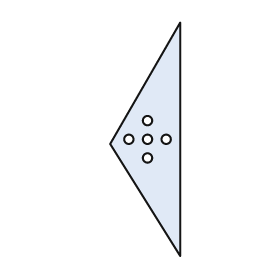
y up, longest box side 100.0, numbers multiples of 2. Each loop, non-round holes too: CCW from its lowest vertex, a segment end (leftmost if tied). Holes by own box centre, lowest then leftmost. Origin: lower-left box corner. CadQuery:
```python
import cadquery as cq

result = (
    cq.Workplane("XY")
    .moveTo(30.0, 0.0)
    .lineTo(30.0, 100.0)
    .lineTo(0.0, 48.0)
    .close()
    .moveTo(16.0, 42.0)
    .circle(2.0)
    .moveTo(8.0, 50.0)
    .circle(2.0)
    .moveTo(16.0, 50.0)
    .circle(2.0)
    .moveTo(24.0, 50.0)
    .circle(2.0)
    .moveTo(16.0, 58.0)
    .circle(2.0)
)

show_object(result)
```